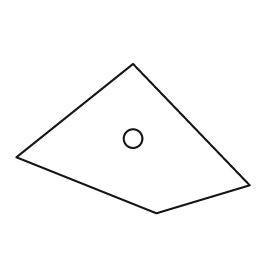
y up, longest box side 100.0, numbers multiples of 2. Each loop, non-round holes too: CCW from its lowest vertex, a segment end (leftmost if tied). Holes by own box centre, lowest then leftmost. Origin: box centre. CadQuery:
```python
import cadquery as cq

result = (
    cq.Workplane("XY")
    .moveTo(10.0, -32.0)
    .lineTo(50.0, -20.0)
    .lineTo(0.0, 32.0)
    .lineTo(-50.0, -8.0)
    .close()
    .moveTo(0.0, 0.0)
    .circle(4.0)
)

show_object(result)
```